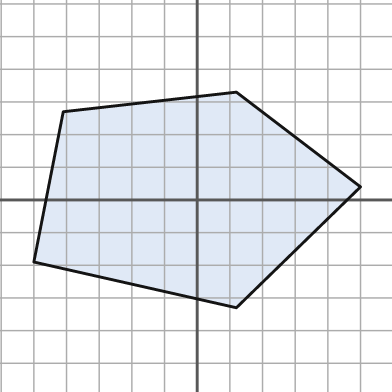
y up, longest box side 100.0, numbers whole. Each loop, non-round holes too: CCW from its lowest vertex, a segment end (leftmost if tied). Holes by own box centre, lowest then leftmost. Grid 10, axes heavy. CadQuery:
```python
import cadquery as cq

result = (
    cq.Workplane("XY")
    .moveTo(12.0, -33.0)
    .lineTo(50.0, 4.0)
    .lineTo(12.0, 33.0)
    .lineTo(-41.0, 27.0)
    .lineTo(-50.0, -19.0)
    .close()
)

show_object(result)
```